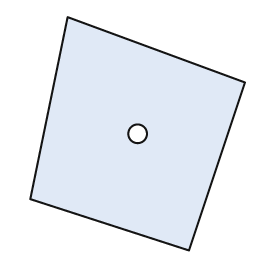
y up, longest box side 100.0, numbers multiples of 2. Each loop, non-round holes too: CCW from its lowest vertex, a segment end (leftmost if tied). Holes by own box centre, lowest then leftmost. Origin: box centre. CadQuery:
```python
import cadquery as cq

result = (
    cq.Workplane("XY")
    .moveTo(22.0, -50.0)
    .lineTo(46.0, 22.0)
    .lineTo(-30.0, 50.0)
    .lineTo(-46.0, -28.0)
    .close()
    .moveTo(0.0, 0.0)
    .circle(4.0)
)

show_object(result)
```